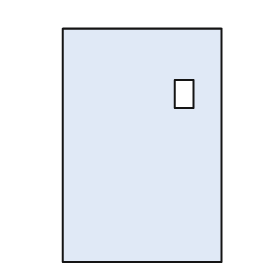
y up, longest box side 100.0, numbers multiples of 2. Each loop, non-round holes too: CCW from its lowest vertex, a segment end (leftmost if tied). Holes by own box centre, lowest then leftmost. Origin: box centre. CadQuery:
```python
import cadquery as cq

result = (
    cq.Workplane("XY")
    .moveTo(-34.0, -50.0)
    .lineTo(34.0, -50.0)
    .lineTo(34.0, 50.0)
    .lineTo(-34.0, 50.0)
    .close()
    .moveTo(14.0, 16.0)
    .lineTo(22.0, 16.0)
    .lineTo(22.0, 28.0)
    .lineTo(14.0, 28.0)
    .close()
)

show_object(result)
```